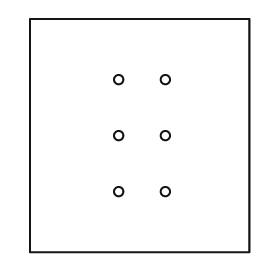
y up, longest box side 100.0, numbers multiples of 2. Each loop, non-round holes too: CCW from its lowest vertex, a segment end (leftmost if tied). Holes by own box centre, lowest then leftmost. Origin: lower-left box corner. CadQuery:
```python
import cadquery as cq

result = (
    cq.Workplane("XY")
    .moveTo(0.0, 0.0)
    .lineTo(94.0, 0.0)
    .lineTo(94.0, 100.0)
    .lineTo(0.0, 100.0)
    .close()
    .moveTo(38.0, 26.0)
    .circle(2.0)
    .moveTo(58.0, 26.0)
    .circle(2.0)
    .moveTo(38.0, 50.0)
    .circle(2.0)
    .moveTo(58.0, 50.0)
    .circle(2.0)
    .moveTo(38.0, 74.0)
    .circle(2.0)
    .moveTo(58.0, 74.0)
    .circle(2.0)
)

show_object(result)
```